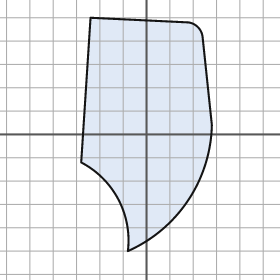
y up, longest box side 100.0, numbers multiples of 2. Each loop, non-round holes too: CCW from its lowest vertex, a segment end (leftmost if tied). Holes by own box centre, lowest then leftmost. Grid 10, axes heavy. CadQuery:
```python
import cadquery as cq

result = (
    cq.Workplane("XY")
    .moveTo(-8.0, -50.0)
    .threePointArc((18.0, -28.0), (28.0, 4.0))
    .lineTo(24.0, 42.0)
    .threePointArc((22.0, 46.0), (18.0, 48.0))
    .lineTo(-24.0, 50.0)
    .lineTo(-28.0, -12.0)
    .threePointArc((-12.0, -28.0), (-8.0, -50.0))
    .close()
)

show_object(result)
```